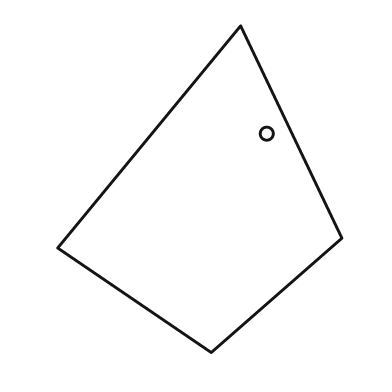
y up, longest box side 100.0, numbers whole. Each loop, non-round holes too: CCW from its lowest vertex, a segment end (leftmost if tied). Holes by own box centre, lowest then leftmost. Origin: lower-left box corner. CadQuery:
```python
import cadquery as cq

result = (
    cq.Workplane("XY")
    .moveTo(47.0, 0.0)
    .lineTo(87.0, 35.0)
    .lineTo(56.0, 100.0)
    .lineTo(0.0, 32.0)
    .close()
    .moveTo(64.0, 67.0)
    .circle(2.0)
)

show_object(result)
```